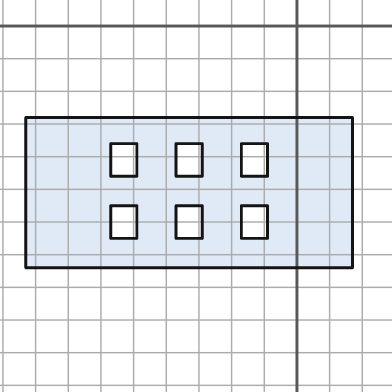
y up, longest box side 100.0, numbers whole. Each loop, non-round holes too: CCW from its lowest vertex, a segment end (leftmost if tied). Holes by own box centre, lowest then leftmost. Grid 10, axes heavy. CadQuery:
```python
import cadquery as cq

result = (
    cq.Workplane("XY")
    .moveTo(-83.0, -74.0)
    .lineTo(17.0, -74.0)
    .lineTo(17.0, -28.0)
    .lineTo(-83.0, -28.0)
    .close()
    .moveTo(-57.0, -65.0)
    .lineTo(-49.0, -65.0)
    .lineTo(-49.0, -55.0)
    .lineTo(-57.0, -55.0)
    .close()
    .moveTo(-37.0, -65.0)
    .lineTo(-29.0, -65.0)
    .lineTo(-29.0, -55.0)
    .lineTo(-37.0, -55.0)
    .close()
    .moveTo(-17.0, -65.0)
    .lineTo(-9.0, -65.0)
    .lineTo(-9.0, -55.0)
    .lineTo(-17.0, -55.0)
    .close()
    .moveTo(-57.0, -46.0)
    .lineTo(-49.0, -46.0)
    .lineTo(-49.0, -36.0)
    .lineTo(-57.0, -36.0)
    .close()
    .moveTo(-37.0, -46.0)
    .lineTo(-29.0, -46.0)
    .lineTo(-29.0, -36.0)
    .lineTo(-37.0, -36.0)
    .close()
    .moveTo(-17.0, -46.0)
    .lineTo(-9.0, -46.0)
    .lineTo(-9.0, -36.0)
    .lineTo(-17.0, -36.0)
    .close()
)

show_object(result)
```